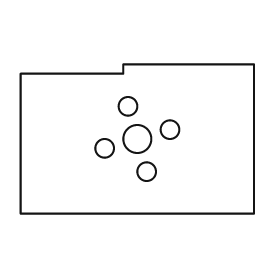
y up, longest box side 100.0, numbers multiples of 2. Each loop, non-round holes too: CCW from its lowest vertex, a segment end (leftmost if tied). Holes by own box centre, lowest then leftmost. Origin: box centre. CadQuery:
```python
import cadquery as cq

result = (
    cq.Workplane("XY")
    .moveTo(-50.0, -32.0)
    .lineTo(50.0, -32.0)
    .lineTo(50.0, 32.0)
    .lineTo(-6.0, 32.0)
    .lineTo(-6.0, 28.0)
    .lineTo(-50.0, 28.0)
    .close()
    .moveTo(4.0, -14.0)
    .circle(4.0)
    .moveTo(-14.0, -4.0)
    .circle(4.0)
    .moveTo(0.0, 0.0)
    .circle(6.0)
    .moveTo(14.0, 4.0)
    .circle(4.0)
    .moveTo(-4.0, 14.0)
    .circle(4.0)
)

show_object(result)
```